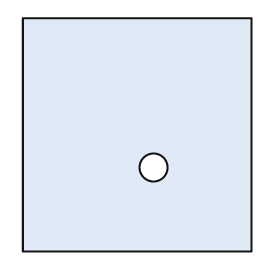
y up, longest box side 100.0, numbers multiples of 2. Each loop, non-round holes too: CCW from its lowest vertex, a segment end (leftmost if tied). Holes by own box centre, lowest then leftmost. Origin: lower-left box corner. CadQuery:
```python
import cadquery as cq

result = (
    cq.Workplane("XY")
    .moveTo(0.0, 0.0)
    .lineTo(98.0, 0.0)
    .lineTo(98.0, 100.0)
    .lineTo(0.0, 100.0)
    .close()
    .moveTo(56.0, 36.0)
    .circle(6.0)
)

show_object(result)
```